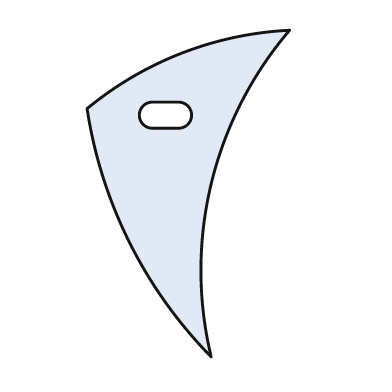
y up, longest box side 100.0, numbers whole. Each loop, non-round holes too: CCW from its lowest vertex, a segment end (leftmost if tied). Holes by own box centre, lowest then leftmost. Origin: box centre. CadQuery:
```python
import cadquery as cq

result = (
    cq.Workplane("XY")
    .moveTo(7.0, -50.0)
    .threePointArc((7.0, 3.0), (31.0, 50.0))
    .threePointArc((-2.0, 43.0), (-31.0, 26.0))
    .threePointArc((-18.0, -15.0), (7.0, -50.0))
    .close()
    .moveTo(-11.0, 20.0)
    .lineTo(-3.0, 20.0)
    .threePointArc((1.0, 24.0), (-3.0, 28.0))
    .lineTo(-11.0, 28.0)
    .threePointArc((-15.0, 24.0), (-11.0, 20.0))
    .close()
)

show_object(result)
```